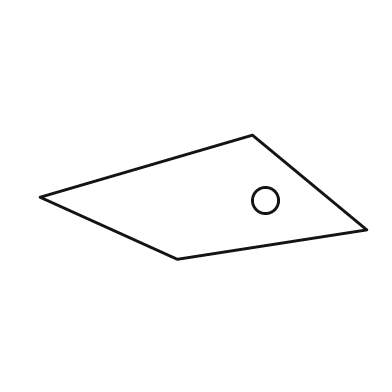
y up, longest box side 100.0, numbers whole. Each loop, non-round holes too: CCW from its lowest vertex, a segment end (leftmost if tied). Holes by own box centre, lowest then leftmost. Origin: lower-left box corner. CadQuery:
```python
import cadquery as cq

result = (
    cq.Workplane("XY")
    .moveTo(42.0, 0.0)
    .lineTo(100.0, 9.0)
    .lineTo(65.0, 38.0)
    .lineTo(0.0, 19.0)
    .close()
    .moveTo(69.0, 18.0)
    .circle(4.0)
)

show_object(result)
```